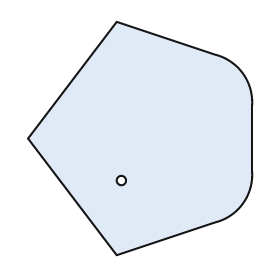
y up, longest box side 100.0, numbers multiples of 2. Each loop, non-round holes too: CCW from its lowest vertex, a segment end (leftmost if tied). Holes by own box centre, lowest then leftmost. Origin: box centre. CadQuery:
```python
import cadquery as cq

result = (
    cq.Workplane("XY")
    .moveTo(-10.0, -50.0)
    .lineTo(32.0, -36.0)
    .threePointArc((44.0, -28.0), (48.0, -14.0))
    .lineTo(48.0, 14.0)
    .threePointArc((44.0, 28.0), (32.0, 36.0))
    .lineTo(-10.0, 50.0)
    .lineTo(-48.0, 0.0)
    .close()
    .moveTo(-8.0, -18.0)
    .circle(2.0)
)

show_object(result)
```